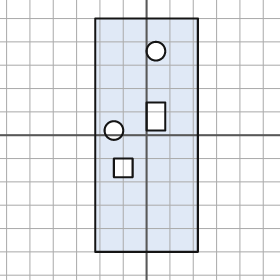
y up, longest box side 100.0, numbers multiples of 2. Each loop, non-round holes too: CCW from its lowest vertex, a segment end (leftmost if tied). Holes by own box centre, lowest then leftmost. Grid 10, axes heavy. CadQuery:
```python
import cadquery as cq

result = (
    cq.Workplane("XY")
    .moveTo(-22.0, -50.0)
    .lineTo(22.0, -50.0)
    .lineTo(22.0, 50.0)
    .lineTo(-22.0, 50.0)
    .close()
    .moveTo(-14.0, -18.0)
    .lineTo(-6.0, -18.0)
    .lineTo(-6.0, -10.0)
    .lineTo(-14.0, -10.0)
    .close()
    .moveTo(-14.0, 2.0)
    .circle(4.0)
    .moveTo(0.0, 2.0)
    .lineTo(8.0, 2.0)
    .lineTo(8.0, 14.0)
    .lineTo(0.0, 14.0)
    .close()
    .moveTo(4.0, 36.0)
    .circle(4.0)
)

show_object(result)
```